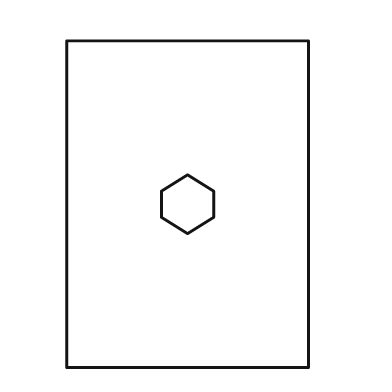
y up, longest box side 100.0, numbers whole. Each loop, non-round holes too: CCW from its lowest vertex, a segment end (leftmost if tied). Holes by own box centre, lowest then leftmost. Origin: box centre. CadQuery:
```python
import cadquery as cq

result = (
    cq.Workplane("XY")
    .moveTo(-37.0, -50.0)
    .lineTo(37.0, -50.0)
    .lineTo(37.0, 50.0)
    .lineTo(-37.0, 50.0)
    .close()
    .moveTo(0.0, -9.0)
    .lineTo(8.0, -4.0)
    .lineTo(8.0, 4.0)
    .lineTo(0.0, 9.0)
    .lineTo(-8.0, 4.0)
    .lineTo(-8.0, -4.0)
    .close()
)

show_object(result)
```